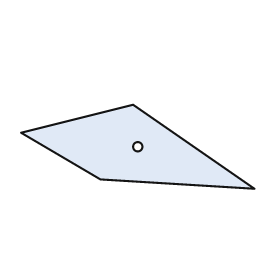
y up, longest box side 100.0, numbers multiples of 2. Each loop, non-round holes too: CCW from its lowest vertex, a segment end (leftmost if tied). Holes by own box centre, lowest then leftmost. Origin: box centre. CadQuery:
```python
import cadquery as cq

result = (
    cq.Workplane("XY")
    .moveTo(50.0, -18.0)
    .lineTo(-2.0, 18.0)
    .lineTo(-50.0, 6.0)
    .lineTo(-16.0, -14.0)
    .close()
    .moveTo(0.0, 0.0)
    .circle(2.0)
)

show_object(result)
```